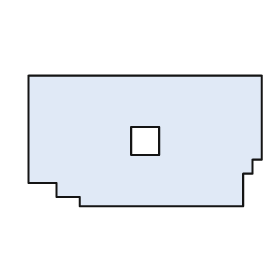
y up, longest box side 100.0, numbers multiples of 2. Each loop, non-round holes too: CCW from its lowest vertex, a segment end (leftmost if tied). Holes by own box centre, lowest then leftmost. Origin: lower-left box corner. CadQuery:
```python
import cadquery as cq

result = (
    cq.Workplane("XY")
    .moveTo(22.0, 0.0)
    .lineTo(92.0, 0.0)
    .lineTo(92.0, 14.0)
    .lineTo(96.0, 14.0)
    .lineTo(96.0, 20.0)
    .lineTo(100.0, 20.0)
    .lineTo(100.0, 56.0)
    .lineTo(0.0, 56.0)
    .lineTo(0.0, 10.0)
    .lineTo(12.0, 10.0)
    .lineTo(12.0, 4.0)
    .lineTo(22.0, 4.0)
    .close()
    .moveTo(44.0, 22.0)
    .lineTo(56.0, 22.0)
    .lineTo(56.0, 34.0)
    .lineTo(44.0, 34.0)
    .close()
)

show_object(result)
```